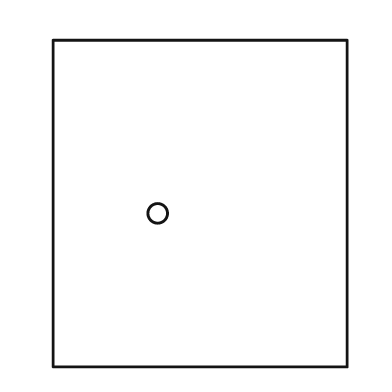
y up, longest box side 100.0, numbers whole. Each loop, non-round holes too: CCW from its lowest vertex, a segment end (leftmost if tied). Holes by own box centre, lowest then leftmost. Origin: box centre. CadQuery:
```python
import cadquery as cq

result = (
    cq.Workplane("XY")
    .moveTo(-45.0, -50.0)
    .lineTo(45.0, -50.0)
    .lineTo(45.0, 50.0)
    .lineTo(-45.0, 50.0)
    .close()
    .moveTo(-13.0, -3.0)
    .circle(3.0)
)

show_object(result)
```